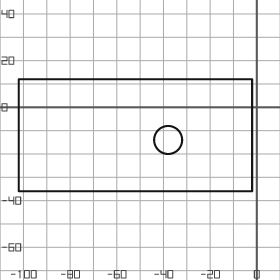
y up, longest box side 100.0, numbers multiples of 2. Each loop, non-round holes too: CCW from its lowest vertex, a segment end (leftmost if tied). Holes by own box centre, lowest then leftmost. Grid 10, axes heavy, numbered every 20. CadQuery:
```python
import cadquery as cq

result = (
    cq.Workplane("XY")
    .moveTo(-102.0, -36.0)
    .lineTo(-2.0, -36.0)
    .lineTo(-2.0, 12.0)
    .lineTo(-102.0, 12.0)
    .close()
    .moveTo(-38.0, -14.0)
    .circle(6.0)
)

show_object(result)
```